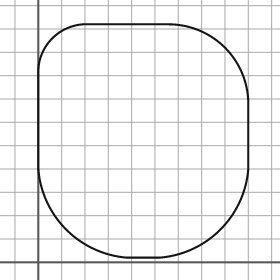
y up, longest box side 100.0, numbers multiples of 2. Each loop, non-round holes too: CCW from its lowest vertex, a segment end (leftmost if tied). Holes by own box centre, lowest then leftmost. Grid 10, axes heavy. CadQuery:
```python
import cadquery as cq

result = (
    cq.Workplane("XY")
    .moveTo(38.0, 2.0)
    .lineTo(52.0, 2.0)
    .threePointArc((78.0, 14.0), (90.0, 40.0))
    .lineTo(90.0, 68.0)
    .threePointArc((80.0, 92.0), (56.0, 102.0))
    .lineTo(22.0, 102.0)
    .threePointArc((6.0, 96.0), (0.0, 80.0))
    .lineTo(0.0, 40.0)
    .threePointArc((12.0, 14.0), (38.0, 2.0))
    .close()
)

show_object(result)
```